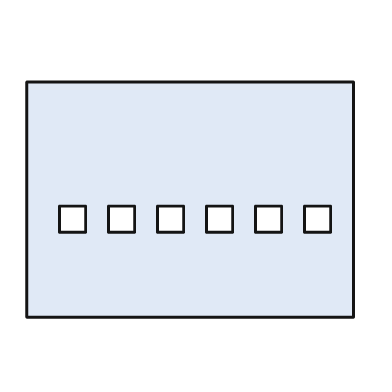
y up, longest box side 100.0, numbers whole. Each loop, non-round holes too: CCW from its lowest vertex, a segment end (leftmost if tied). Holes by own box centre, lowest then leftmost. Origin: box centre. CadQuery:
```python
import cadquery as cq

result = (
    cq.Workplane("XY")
    .moveTo(-50.0, -36.0)
    .lineTo(50.0, -36.0)
    .lineTo(50.0, 36.0)
    .lineTo(-50.0, 36.0)
    .close()
    .moveTo(-40.0, -10.0)
    .lineTo(-32.0, -10.0)
    .lineTo(-32.0, -2.0)
    .lineTo(-40.0, -2.0)
    .close()
    .moveTo(-25.0, -10.0)
    .lineTo(-17.0, -10.0)
    .lineTo(-17.0, -2.0)
    .lineTo(-25.0, -2.0)
    .close()
    .moveTo(-10.0, -10.0)
    .lineTo(-2.0, -10.0)
    .lineTo(-2.0, -2.0)
    .lineTo(-10.0, -2.0)
    .close()
    .moveTo(5.0, -10.0)
    .lineTo(13.0, -10.0)
    .lineTo(13.0, -2.0)
    .lineTo(5.0, -2.0)
    .close()
    .moveTo(20.0, -10.0)
    .lineTo(28.0, -10.0)
    .lineTo(28.0, -2.0)
    .lineTo(20.0, -2.0)
    .close()
    .moveTo(35.0, -10.0)
    .lineTo(43.0, -10.0)
    .lineTo(43.0, -2.0)
    .lineTo(35.0, -2.0)
    .close()
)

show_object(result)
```